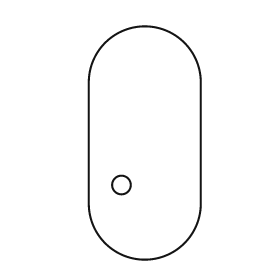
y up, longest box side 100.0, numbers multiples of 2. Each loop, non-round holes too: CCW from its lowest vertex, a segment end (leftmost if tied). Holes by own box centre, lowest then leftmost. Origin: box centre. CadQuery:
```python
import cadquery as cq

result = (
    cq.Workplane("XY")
    .moveTo(-24.0, -26.0)
    .threePointArc((0.0, -50.0), (24.0, -26.0))
    .lineTo(24.0, 26.0)
    .threePointArc((0.0, 50.0), (-24.0, 26.0))
    .close()
    .moveTo(-10.0, -18.0)
    .circle(4.0)
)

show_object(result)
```